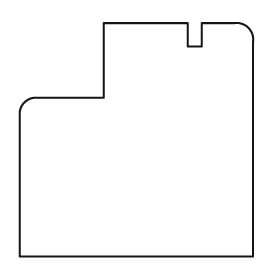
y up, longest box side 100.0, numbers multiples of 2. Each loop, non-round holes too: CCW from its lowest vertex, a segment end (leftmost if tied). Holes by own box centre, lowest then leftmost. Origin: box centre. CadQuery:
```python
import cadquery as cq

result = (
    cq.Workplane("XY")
    .moveTo(-50.0, -50.0)
    .lineTo(50.0, -50.0)
    .lineTo(50.0, 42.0)
    .threePointArc((48.0, 48.0), (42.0, 50.0))
    .lineTo(28.0, 50.0)
    .lineTo(28.0, 40.0)
    .lineTo(22.0, 40.0)
    .lineTo(22.0, 50.0)
    .lineTo(-14.0, 50.0)
    .lineTo(-14.0, 18.0)
    .lineTo(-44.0, 18.0)
    .threePointArc((-48.0, 16.0), (-50.0, 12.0))
    .close()
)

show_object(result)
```